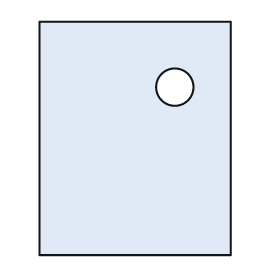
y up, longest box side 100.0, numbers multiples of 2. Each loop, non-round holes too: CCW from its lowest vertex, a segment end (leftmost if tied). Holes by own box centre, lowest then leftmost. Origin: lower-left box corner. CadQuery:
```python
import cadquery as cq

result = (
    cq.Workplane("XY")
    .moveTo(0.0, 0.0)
    .lineTo(82.0, 0.0)
    .lineTo(82.0, 100.0)
    .lineTo(0.0, 100.0)
    .close()
    .moveTo(58.0, 72.0)
    .circle(8.0)
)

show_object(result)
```